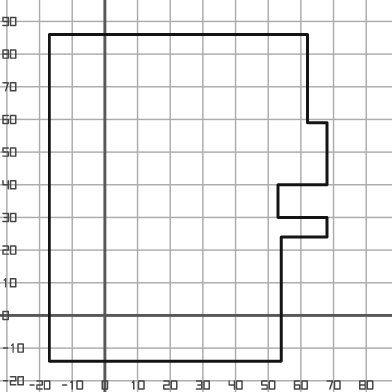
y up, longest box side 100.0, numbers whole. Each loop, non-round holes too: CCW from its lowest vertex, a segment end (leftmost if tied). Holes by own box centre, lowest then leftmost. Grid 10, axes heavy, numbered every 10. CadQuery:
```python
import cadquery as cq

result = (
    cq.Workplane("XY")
    .moveTo(-17.0, -14.0)
    .lineTo(54.0, -14.0)
    .lineTo(54.0, 24.0)
    .lineTo(68.0, 24.0)
    .lineTo(68.0, 30.0)
    .lineTo(53.0, 30.0)
    .lineTo(53.0, 40.0)
    .lineTo(68.0, 40.0)
    .lineTo(68.0, 59.0)
    .lineTo(62.0, 59.0)
    .lineTo(62.0, 86.0)
    .lineTo(-17.0, 86.0)
    .close()
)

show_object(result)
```